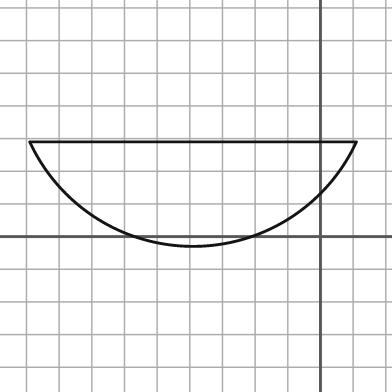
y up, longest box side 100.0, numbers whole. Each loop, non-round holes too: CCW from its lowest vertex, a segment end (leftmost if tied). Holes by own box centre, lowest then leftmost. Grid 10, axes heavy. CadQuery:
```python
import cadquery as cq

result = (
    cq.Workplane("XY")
    .moveTo(-89.0, 29.0)
    .threePointArc((-39.0, -3.0), (11.0, 29.0))
    .close()
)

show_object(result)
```